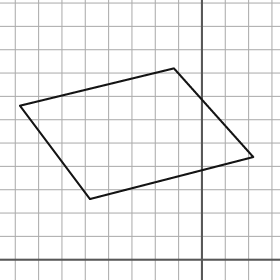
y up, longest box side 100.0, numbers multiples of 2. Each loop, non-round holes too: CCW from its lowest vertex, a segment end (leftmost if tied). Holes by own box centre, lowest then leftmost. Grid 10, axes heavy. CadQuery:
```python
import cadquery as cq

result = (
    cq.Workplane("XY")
    .moveTo(-48.0, 26.0)
    .lineTo(22.0, 44.0)
    .lineTo(-12.0, 82.0)
    .lineTo(-78.0, 66.0)
    .close()
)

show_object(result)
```